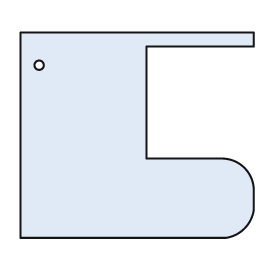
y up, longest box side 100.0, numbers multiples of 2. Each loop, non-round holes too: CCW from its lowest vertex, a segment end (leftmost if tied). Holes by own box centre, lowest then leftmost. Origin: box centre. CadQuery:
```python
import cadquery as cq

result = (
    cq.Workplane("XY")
    .moveTo(-50.0, -44.0)
    .lineTo(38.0, -44.0)
    .threePointArc((46.0, -40.0), (50.0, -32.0))
    .lineTo(50.0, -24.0)
    .threePointArc((46.0, -14.0), (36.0, -10.0))
    .lineTo(4.0, -10.0)
    .lineTo(4.0, 38.0)
    .lineTo(50.0, 38.0)
    .lineTo(50.0, 44.0)
    .lineTo(-50.0, 44.0)
    .close()
    .moveTo(-42.0, 30.0)
    .circle(2.0)
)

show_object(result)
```